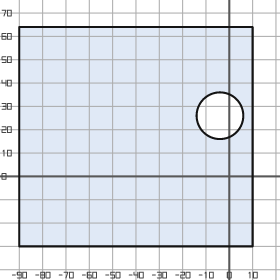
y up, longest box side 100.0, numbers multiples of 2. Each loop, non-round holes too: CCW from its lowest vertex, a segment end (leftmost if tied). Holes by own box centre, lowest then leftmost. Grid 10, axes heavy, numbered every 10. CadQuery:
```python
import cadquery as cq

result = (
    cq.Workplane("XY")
    .moveTo(-90.0, -30.0)
    .lineTo(10.0, -30.0)
    .lineTo(10.0, 64.0)
    .lineTo(-90.0, 64.0)
    .close()
    .moveTo(-4.0, 26.0)
    .circle(10.0)
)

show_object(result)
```